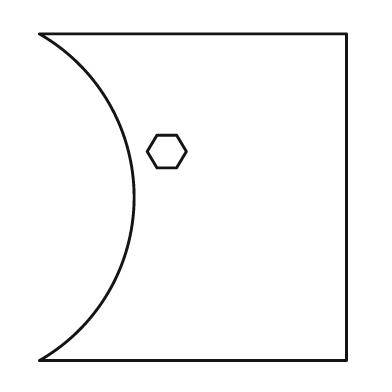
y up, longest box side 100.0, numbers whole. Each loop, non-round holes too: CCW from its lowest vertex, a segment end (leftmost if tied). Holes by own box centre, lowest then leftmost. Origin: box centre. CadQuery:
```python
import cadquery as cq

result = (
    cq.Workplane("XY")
    .moveTo(-47.0, -50.0)
    .lineTo(47.0, -50.0)
    .lineTo(47.0, 50.0)
    .lineTo(-47.0, 50.0)
    .threePointArc((-18.0, 0.0), (-47.0, -50.0))
    .close()
    .moveTo(-11.0, 9.0)
    .lineTo(-5.0, 9.0)
    .lineTo(-2.0, 14.0)
    .lineTo(-5.0, 19.0)
    .lineTo(-11.0, 19.0)
    .lineTo(-14.0, 14.0)
    .close()
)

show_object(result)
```